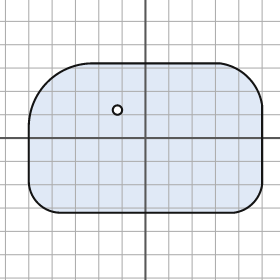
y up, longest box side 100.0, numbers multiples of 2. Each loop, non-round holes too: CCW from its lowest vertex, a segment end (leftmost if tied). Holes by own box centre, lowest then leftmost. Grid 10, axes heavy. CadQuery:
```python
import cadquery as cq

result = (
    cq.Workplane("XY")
    .moveTo(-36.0, -32.0)
    .lineTo(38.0, -32.0)
    .threePointArc((46.0, -28.0), (50.0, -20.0))
    .lineTo(50.0, 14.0)
    .threePointArc((44.0, 26.0), (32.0, 32.0))
    .lineTo(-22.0, 32.0)
    .threePointArc((-42.0, 24.0), (-50.0, 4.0))
    .lineTo(-50.0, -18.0)
    .threePointArc((-46.0, -28.0), (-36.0, -32.0))
    .close()
    .moveTo(-12.0, 12.0)
    .circle(2.0)
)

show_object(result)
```